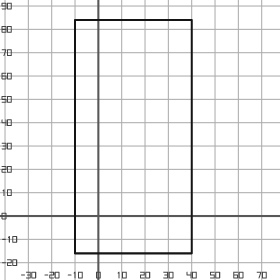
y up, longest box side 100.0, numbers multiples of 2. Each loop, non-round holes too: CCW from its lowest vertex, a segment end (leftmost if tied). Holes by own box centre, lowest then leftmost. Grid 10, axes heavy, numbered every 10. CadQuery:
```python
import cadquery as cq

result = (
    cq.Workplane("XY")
    .moveTo(-10.0, -16.0)
    .lineTo(40.0, -16.0)
    .lineTo(40.0, 84.0)
    .lineTo(-10.0, 84.0)
    .close()
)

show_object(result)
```